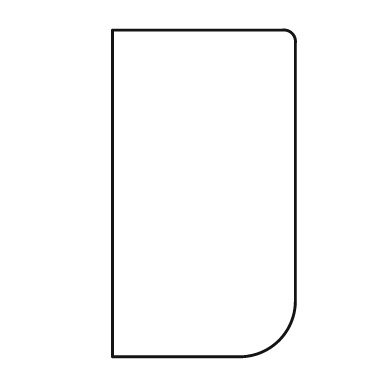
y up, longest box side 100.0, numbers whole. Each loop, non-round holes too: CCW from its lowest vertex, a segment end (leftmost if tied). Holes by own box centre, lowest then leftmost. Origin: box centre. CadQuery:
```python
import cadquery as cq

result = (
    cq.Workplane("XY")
    .moveTo(-28.0, -50.0)
    .lineTo(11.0, -50.0)
    .threePointArc((23.0, -45.0), (28.0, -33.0))
    .lineTo(28.0, 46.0)
    .threePointArc((27.0, 49.0), (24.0, 50.0))
    .lineTo(-28.0, 50.0)
    .close()
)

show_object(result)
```